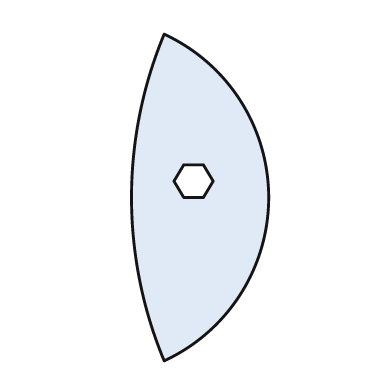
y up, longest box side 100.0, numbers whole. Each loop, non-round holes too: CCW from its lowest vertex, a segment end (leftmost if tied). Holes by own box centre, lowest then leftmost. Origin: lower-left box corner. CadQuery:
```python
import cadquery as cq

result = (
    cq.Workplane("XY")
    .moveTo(10.0, 0.0)
    .threePointArc((42.0, 50.0), (10.0, 100.0))
    .threePointArc((0.0, 50.0), (10.0, 0.0))
    .close()
    .moveTo(16.0, 50.0)
    .lineTo(22.0, 50.0)
    .lineTo(25.0, 55.0)
    .lineTo(22.0, 60.0)
    .lineTo(16.0, 60.0)
    .lineTo(13.0, 55.0)
    .close()
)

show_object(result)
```